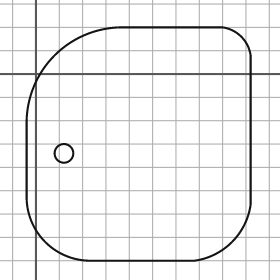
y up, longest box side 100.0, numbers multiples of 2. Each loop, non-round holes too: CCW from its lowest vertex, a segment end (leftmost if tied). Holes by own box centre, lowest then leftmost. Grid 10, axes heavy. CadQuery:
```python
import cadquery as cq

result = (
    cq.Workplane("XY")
    .moveTo(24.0, -80.0)
    .lineTo(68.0, -80.0)
    .threePointArc((84.0, -72.0), (92.0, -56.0))
    .lineTo(92.0, 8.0)
    .threePointArc((88.0, 16.0), (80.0, 20.0))
    .lineTo(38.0, 20.0)
    .threePointArc((8.0, 8.0), (-4.0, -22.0))
    .lineTo(-4.0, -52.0)
    .threePointArc((4.0, -72.0), (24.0, -80.0))
    .close()
    .moveTo(12.0, -34.0)
    .circle(4.0)
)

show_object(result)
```